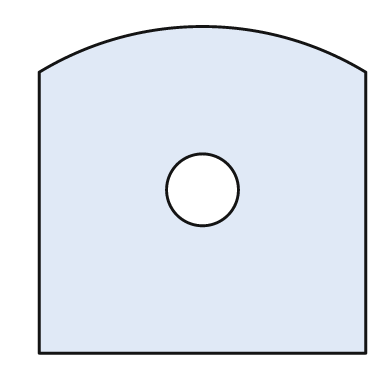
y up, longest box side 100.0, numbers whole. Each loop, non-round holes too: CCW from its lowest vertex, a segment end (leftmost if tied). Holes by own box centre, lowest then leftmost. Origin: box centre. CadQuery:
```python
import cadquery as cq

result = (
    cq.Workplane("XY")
    .moveTo(-50.0, -50.0)
    .lineTo(50.0, -50.0)
    .lineTo(50.0, 36.0)
    .threePointArc((0.0, 50.0), (-50.0, 36.0))
    .close()
    .moveTo(0.0, 0.0)
    .circle(11.0)
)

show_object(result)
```